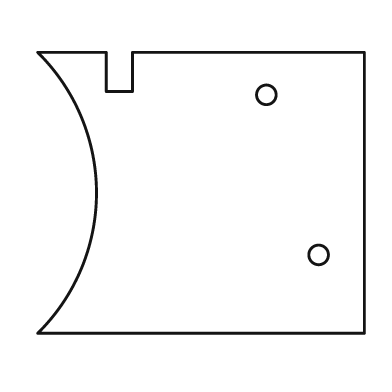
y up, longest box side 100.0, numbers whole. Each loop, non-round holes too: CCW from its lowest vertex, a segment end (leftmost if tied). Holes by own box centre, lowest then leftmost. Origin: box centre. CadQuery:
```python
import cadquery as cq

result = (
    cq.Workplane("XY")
    .moveTo(-50.0, -43.0)
    .lineTo(50.0, -43.0)
    .lineTo(50.0, 43.0)
    .lineTo(-21.0, 43.0)
    .lineTo(-21.0, 31.0)
    .lineTo(-29.0, 31.0)
    .lineTo(-29.0, 43.0)
    .lineTo(-50.0, 43.0)
    .threePointArc((-32.0, 0.0), (-50.0, -43.0))
    .close()
    .moveTo(36.0, -19.0)
    .circle(3.0)
    .moveTo(20.0, 30.0)
    .circle(3.0)
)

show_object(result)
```